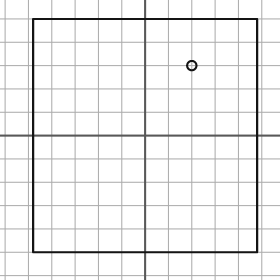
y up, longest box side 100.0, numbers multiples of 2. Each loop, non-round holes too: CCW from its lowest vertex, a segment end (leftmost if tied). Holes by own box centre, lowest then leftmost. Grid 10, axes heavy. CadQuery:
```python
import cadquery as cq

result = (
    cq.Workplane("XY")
    .moveTo(-48.0, -50.0)
    .lineTo(48.0, -50.0)
    .lineTo(48.0, 50.0)
    .lineTo(-48.0, 50.0)
    .close()
    .moveTo(20.0, 30.0)
    .circle(2.0)
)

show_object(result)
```